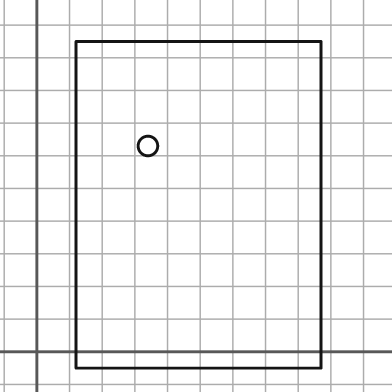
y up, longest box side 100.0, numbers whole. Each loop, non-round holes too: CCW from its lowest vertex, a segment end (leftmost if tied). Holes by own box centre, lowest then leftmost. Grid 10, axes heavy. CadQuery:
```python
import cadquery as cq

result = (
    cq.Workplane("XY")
    .moveTo(12.0, -5.0)
    .lineTo(87.0, -5.0)
    .lineTo(87.0, 95.0)
    .lineTo(12.0, 95.0)
    .close()
    .moveTo(34.0, 63.0)
    .circle(3.0)
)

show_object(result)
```